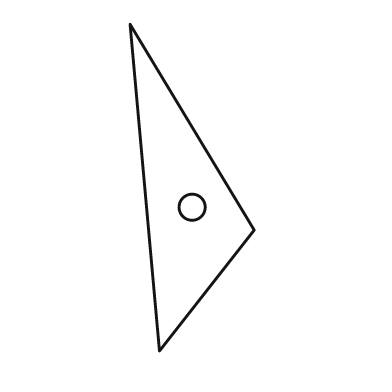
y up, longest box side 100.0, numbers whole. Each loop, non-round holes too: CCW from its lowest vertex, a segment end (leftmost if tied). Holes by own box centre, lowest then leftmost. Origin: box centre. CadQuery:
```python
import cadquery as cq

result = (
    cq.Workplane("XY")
    .moveTo(-10.0, -50.0)
    .lineTo(19.0, -13.0)
    .lineTo(-19.0, 50.0)
    .close()
    .moveTo(0.0, -6.0)
    .circle(4.0)
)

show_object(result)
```